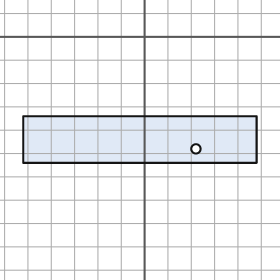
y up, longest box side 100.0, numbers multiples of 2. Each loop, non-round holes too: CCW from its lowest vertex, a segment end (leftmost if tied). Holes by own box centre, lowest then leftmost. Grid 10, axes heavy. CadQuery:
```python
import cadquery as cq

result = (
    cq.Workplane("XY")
    .moveTo(-52.0, -54.0)
    .lineTo(48.0, -54.0)
    .lineTo(48.0, -34.0)
    .lineTo(-52.0, -34.0)
    .close()
    .moveTo(22.0, -48.0)
    .circle(2.0)
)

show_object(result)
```